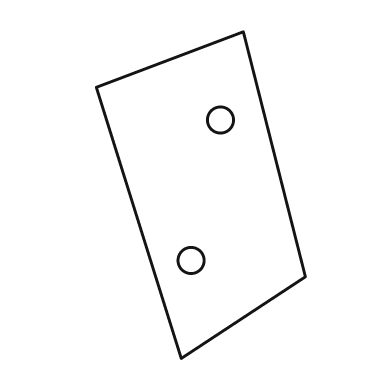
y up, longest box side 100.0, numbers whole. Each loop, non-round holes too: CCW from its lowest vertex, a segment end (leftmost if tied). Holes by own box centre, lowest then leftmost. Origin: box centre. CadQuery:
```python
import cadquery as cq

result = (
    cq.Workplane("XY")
    .moveTo(-6.0, -50.0)
    .lineTo(32.0, -25.0)
    .lineTo(13.0, 50.0)
    .lineTo(-32.0, 33.0)
    .close()
    .moveTo(-3.0, -20.0)
    .circle(4.0)
    .moveTo(6.0, 23.0)
    .circle(4.0)
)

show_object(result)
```